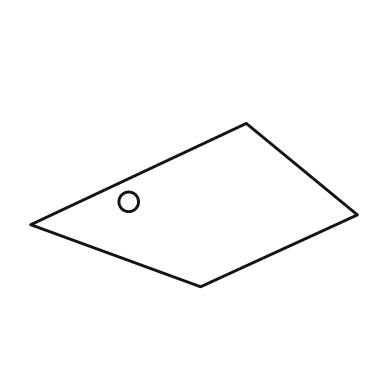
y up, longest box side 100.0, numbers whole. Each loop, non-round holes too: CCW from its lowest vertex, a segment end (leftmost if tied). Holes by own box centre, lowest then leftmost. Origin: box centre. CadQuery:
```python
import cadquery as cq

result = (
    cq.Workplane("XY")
    .moveTo(2.0, -25.0)
    .lineTo(50.0, -3.0)
    .lineTo(16.0, 25.0)
    .lineTo(-50.0, -6.0)
    .close()
    .moveTo(-20.0, 1.0)
    .circle(3.0)
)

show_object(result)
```